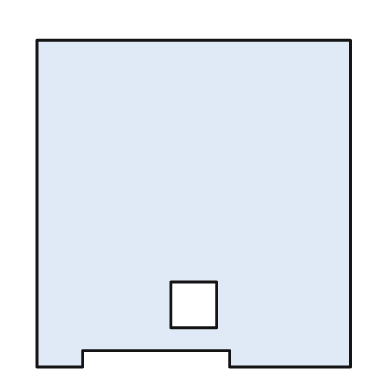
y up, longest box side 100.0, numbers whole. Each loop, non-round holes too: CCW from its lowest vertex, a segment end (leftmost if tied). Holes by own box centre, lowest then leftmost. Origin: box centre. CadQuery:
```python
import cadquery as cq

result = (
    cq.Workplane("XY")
    .moveTo(-48.0, -50.0)
    .lineTo(-34.0, -50.0)
    .lineTo(-34.0, -45.0)
    .lineTo(11.0, -45.0)
    .lineTo(11.0, -50.0)
    .lineTo(48.0, -50.0)
    .lineTo(48.0, 50.0)
    .lineTo(-48.0, 50.0)
    .close()
    .moveTo(-7.0, -38.0)
    .lineTo(7.0, -38.0)
    .lineTo(7.0, -24.0)
    .lineTo(-7.0, -24.0)
    .close()
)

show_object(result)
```